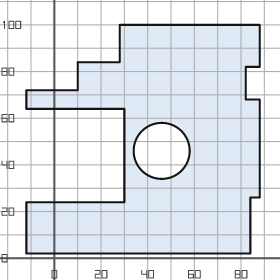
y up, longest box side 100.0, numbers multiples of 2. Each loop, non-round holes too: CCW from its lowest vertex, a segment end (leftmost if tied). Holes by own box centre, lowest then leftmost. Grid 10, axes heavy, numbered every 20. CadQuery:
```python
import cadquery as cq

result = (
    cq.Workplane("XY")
    .moveTo(-12.0, 2.0)
    .lineTo(84.0, 2.0)
    .lineTo(84.0, 26.0)
    .lineTo(88.0, 26.0)
    .lineTo(88.0, 68.0)
    .lineTo(82.0, 68.0)
    .lineTo(82.0, 82.0)
    .lineTo(88.0, 82.0)
    .lineTo(88.0, 100.0)
    .lineTo(28.0, 100.0)
    .lineTo(28.0, 84.0)
    .lineTo(10.0, 84.0)
    .lineTo(10.0, 72.0)
    .lineTo(-12.0, 72.0)
    .lineTo(-12.0, 64.0)
    .lineTo(30.0, 64.0)
    .lineTo(30.0, 24.0)
    .lineTo(-12.0, 24.0)
    .close()
    .moveTo(46.0, 46.0)
    .circle(12.0)
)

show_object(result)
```